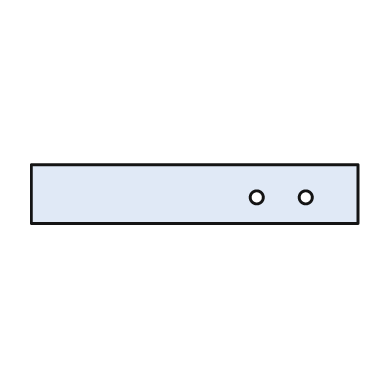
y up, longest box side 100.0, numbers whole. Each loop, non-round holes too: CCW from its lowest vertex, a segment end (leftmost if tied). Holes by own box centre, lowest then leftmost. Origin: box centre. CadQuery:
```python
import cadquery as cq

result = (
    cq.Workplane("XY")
    .moveTo(-50.0, -9.0)
    .lineTo(50.0, -9.0)
    .lineTo(50.0, 9.0)
    .lineTo(-50.0, 9.0)
    .close()
    .moveTo(19.0, -1.0)
    .circle(2.0)
    .moveTo(34.0, -1.0)
    .circle(2.0)
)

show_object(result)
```